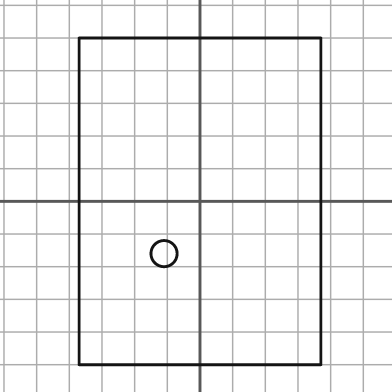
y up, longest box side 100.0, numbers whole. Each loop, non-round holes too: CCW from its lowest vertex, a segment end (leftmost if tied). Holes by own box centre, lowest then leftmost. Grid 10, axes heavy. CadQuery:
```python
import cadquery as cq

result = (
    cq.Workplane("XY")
    .moveTo(-37.0, -50.0)
    .lineTo(37.0, -50.0)
    .lineTo(37.0, 50.0)
    .lineTo(-37.0, 50.0)
    .close()
    .moveTo(-11.0, -16.0)
    .circle(4.0)
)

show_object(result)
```